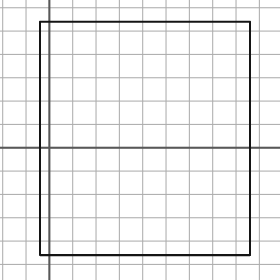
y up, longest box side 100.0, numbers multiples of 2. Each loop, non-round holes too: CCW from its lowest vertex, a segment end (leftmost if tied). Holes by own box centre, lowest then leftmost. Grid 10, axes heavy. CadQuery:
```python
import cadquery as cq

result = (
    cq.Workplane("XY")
    .moveTo(-4.0, -46.0)
    .lineTo(86.0, -46.0)
    .lineTo(86.0, 54.0)
    .lineTo(-4.0, 54.0)
    .close()
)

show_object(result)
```